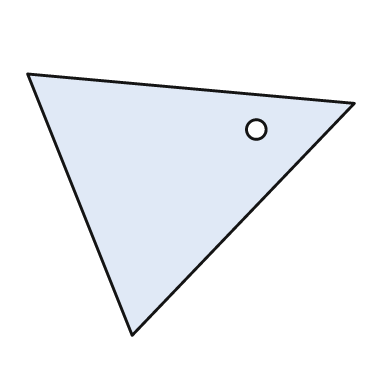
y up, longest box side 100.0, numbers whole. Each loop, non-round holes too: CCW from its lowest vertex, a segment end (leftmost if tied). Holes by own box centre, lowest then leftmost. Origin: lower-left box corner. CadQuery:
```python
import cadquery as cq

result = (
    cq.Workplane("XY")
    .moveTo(32.0, 0.0)
    .lineTo(100.0, 71.0)
    .lineTo(0.0, 80.0)
    .close()
    .moveTo(70.0, 63.0)
    .circle(3.0)
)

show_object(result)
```